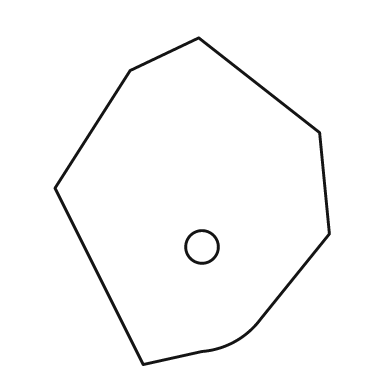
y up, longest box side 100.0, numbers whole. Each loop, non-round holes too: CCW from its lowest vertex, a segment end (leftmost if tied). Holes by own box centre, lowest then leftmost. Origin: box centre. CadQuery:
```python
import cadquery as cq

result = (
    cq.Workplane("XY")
    .moveTo(-15.0, -50.0)
    .lineTo(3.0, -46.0)
    .threePointArc((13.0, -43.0), (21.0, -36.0))
    .lineTo(42.0, -10.0)
    .lineTo(39.0, 21.0)
    .lineTo(2.0, 50.0)
    .lineTo(-19.0, 40.0)
    .lineTo(-42.0, 4.0)
    .close()
    .moveTo(3.0, -14.0)
    .circle(5.0)
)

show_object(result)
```